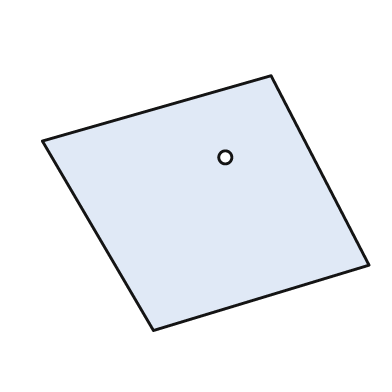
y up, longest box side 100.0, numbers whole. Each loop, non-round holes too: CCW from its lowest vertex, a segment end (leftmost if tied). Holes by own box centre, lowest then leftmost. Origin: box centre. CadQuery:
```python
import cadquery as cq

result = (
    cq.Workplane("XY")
    .moveTo(-16.0, -39.0)
    .lineTo(50.0, -19.0)
    .lineTo(20.0, 39.0)
    .lineTo(-50.0, 19.0)
    .close()
    .moveTo(6.0, 14.0)
    .circle(2.0)
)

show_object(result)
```